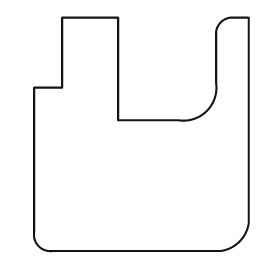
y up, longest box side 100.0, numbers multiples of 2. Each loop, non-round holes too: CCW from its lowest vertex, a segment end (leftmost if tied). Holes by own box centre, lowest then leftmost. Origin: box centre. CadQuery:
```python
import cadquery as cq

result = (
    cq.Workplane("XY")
    .moveTo(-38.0, -50.0)
    .lineTo(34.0, -50.0)
    .threePointArc((42.0, -46.0), (46.0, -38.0))
    .lineTo(46.0, 50.0)
    .lineTo(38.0, 50.0)
    .threePointArc((34.0, 48.0), (32.0, 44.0))
    .lineTo(32.0, 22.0)
    .threePointArc((28.0, 10.0), (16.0, 6.0))
    .lineTo(-10.0, 6.0)
    .lineTo(-10.0, 50.0)
    .lineTo(-34.0, 50.0)
    .lineTo(-34.0, 20.0)
    .lineTo(-46.0, 20.0)
    .lineTo(-46.0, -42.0)
    .threePointArc((-44.0, -48.0), (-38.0, -50.0))
    .close()
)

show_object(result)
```